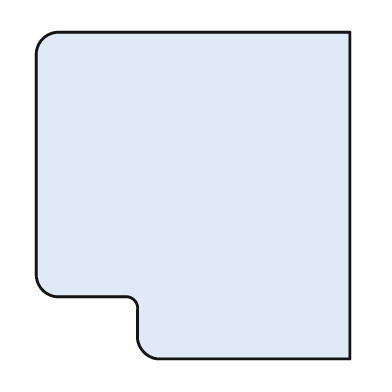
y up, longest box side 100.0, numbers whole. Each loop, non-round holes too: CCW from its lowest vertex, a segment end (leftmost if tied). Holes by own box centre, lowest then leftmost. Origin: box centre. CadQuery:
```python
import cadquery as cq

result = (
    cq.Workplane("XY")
    .moveTo(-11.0, -50.0)
    .lineTo(48.0, -50.0)
    .lineTo(48.0, 50.0)
    .lineTo(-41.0, 50.0)
    .threePointArc((-46.0, 48.0), (-48.0, 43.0))
    .lineTo(-48.0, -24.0)
    .threePointArc((-46.0, -29.0), (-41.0, -31.0))
    .lineTo(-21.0, -31.0)
    .threePointArc((-18.0, -32.0), (-17.0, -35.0))
    .lineTo(-17.0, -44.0)
    .threePointArc((-15.0, -48.0), (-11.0, -50.0))
    .close()
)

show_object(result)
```